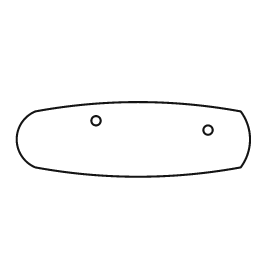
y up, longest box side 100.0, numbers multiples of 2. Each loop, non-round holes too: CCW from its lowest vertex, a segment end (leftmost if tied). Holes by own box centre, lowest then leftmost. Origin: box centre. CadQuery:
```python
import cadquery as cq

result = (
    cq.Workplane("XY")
    .moveTo(-42.0, -12.0)
    .threePointArc((2.0, -16.0), (46.0, -12.0))
    .threePointArc((50.0, 0.0), (46.0, 12.0))
    .threePointArc((2.0, 16.0), (-42.0, 12.0))
    .threePointArc((-50.0, 0.0), (-42.0, -12.0))
    .close()
    .moveTo(32.0, 4.0)
    .circle(2.0)
    .moveTo(-16.0, 8.0)
    .circle(2.0)
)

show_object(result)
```